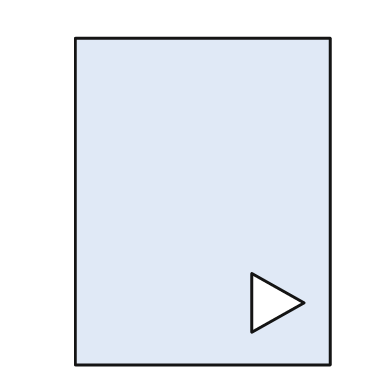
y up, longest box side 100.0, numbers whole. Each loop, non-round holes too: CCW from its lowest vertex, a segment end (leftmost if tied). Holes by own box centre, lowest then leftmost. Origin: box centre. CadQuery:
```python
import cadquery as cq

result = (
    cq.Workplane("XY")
    .moveTo(-39.0, -50.0)
    .lineTo(39.0, -50.0)
    .lineTo(39.0, 50.0)
    .lineTo(-39.0, 50.0)
    .close()
    .moveTo(15.0, -40.0)
    .lineTo(31.0, -31.0)
    .lineTo(15.0, -22.0)
    .close()
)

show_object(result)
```